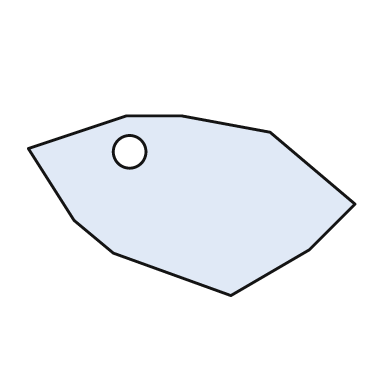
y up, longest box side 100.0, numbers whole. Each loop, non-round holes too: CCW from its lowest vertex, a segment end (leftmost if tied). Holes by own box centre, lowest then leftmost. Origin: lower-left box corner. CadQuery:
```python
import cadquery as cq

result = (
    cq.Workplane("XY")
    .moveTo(62.0, 0.0)
    .lineTo(86.0, 14.0)
    .lineTo(100.0, 28.0)
    .lineTo(74.0, 50.0)
    .lineTo(47.0, 55.0)
    .lineTo(30.0, 55.0)
    .lineTo(0.0, 45.0)
    .lineTo(14.0, 23.0)
    .lineTo(26.0, 13.0)
    .close()
    .moveTo(31.0, 44.0)
    .circle(5.0)
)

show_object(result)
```